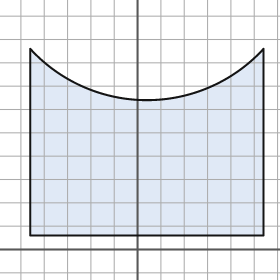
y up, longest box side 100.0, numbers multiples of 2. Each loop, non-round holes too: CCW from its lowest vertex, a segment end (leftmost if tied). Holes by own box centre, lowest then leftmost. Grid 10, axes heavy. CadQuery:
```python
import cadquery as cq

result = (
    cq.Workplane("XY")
    .moveTo(-46.0, 6.0)
    .lineTo(54.0, 6.0)
    .lineTo(54.0, 86.0)
    .threePointArc((4.0, 64.0), (-46.0, 86.0))
    .close()
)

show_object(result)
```